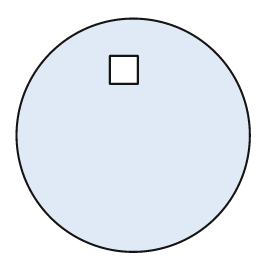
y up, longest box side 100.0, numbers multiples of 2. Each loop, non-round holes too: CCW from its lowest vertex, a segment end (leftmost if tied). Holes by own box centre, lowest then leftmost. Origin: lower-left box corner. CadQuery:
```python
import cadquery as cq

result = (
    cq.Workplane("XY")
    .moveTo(50.0, 50.0)
    .circle(50.0)
    .moveTo(40.0, 72.0)
    .lineTo(52.0, 72.0)
    .lineTo(52.0, 84.0)
    .lineTo(40.0, 84.0)
    .close()
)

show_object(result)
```